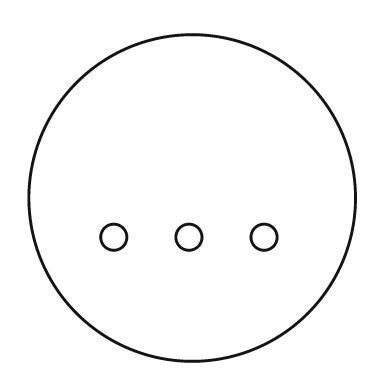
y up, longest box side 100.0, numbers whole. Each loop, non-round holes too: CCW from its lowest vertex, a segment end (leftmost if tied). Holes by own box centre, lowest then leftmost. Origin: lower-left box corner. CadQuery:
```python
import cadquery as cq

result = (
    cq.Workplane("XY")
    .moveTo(50.0, 50.0)
    .circle(50.0)
    .moveTo(26.0, 38.0)
    .circle(4.0)
    .moveTo(49.0, 38.0)
    .circle(4.0)
    .moveTo(72.0, 38.0)
    .circle(4.0)
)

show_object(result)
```